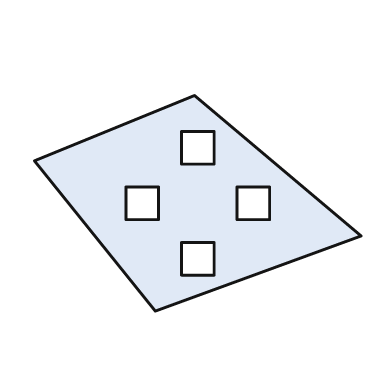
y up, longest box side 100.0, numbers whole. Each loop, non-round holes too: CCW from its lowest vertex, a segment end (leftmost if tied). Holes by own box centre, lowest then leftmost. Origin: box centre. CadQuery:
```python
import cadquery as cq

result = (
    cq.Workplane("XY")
    .moveTo(-13.0, -33.0)
    .lineTo(50.0, -10.0)
    .lineTo(-1.0, 33.0)
    .lineTo(-50.0, 13.0)
    .close()
    .moveTo(-5.0, -22.0)
    .lineTo(5.0, -22.0)
    .lineTo(5.0, -12.0)
    .lineTo(-5.0, -12.0)
    .close()
    .moveTo(-22.0, -5.0)
    .lineTo(-12.0, -5.0)
    .lineTo(-12.0, 5.0)
    .lineTo(-22.0, 5.0)
    .close()
    .moveTo(12.0, -5.0)
    .lineTo(22.0, -5.0)
    .lineTo(22.0, 5.0)
    .lineTo(12.0, 5.0)
    .close()
    .moveTo(-5.0, 12.0)
    .lineTo(5.0, 12.0)
    .lineTo(5.0, 22.0)
    .lineTo(-5.0, 22.0)
    .close()
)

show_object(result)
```